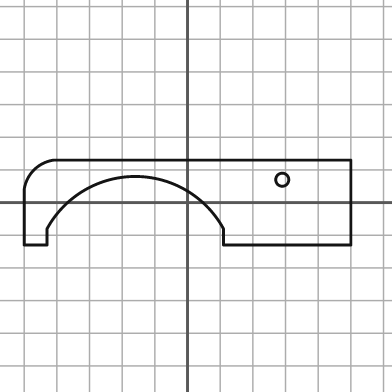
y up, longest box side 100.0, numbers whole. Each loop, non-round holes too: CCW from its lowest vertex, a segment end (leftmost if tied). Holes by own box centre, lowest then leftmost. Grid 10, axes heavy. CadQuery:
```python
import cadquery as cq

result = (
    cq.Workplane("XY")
    .moveTo(-50.0, -13.0)
    .lineTo(-43.0, -13.0)
    .lineTo(-43.0, -8.0)
    .threePointArc((-16.0, 8.0), (11.0, -8.0))
    .lineTo(11.0, -13.0)
    .lineTo(50.0, -13.0)
    .lineTo(50.0, 13.0)
    .lineTo(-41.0, 13.0)
    .threePointArc((-47.0, 10.0), (-50.0, 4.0))
    .close()
    .moveTo(29.0, 7.0)
    .circle(2.0)
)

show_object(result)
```